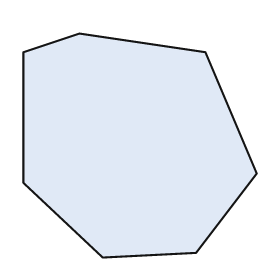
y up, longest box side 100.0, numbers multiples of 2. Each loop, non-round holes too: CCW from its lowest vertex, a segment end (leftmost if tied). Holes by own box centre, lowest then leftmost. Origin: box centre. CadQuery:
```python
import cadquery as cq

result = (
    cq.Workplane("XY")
    .moveTo(-16.0, -48.0)
    .lineTo(24.0, -46.0)
    .lineTo(50.0, -12.0)
    .lineTo(28.0, 40.0)
    .lineTo(-26.0, 48.0)
    .lineTo(-50.0, 40.0)
    .lineTo(-50.0, -16.0)
    .close()
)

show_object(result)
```